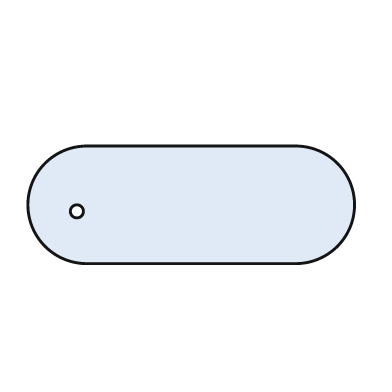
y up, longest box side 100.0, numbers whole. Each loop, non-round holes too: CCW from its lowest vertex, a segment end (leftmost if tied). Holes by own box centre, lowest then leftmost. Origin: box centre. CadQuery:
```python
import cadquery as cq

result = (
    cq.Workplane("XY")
    .moveTo(-32.0, -18.0)
    .lineTo(32.0, -18.0)
    .threePointArc((50.0, 0.0), (32.0, 18.0))
    .lineTo(-32.0, 18.0)
    .threePointArc((-50.0, 0.0), (-32.0, -18.0))
    .close()
    .moveTo(-35.0, -2.0)
    .circle(2.0)
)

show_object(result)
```